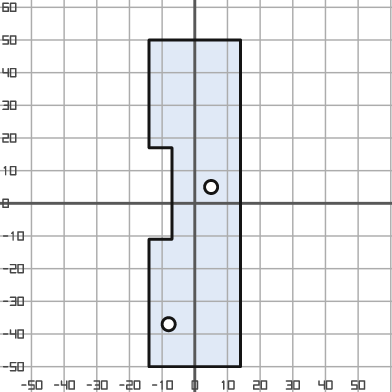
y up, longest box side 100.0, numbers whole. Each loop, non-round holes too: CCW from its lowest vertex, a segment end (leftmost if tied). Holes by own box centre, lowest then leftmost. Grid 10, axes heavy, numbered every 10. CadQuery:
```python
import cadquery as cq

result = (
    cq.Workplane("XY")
    .moveTo(-14.0, -50.0)
    .lineTo(14.0, -50.0)
    .lineTo(14.0, 50.0)
    .lineTo(-14.0, 50.0)
    .lineTo(-14.0, 17.0)
    .lineTo(-7.0, 17.0)
    .lineTo(-7.0, -11.0)
    .lineTo(-14.0, -11.0)
    .close()
    .moveTo(-8.0, -37.0)
    .circle(2.0)
    .moveTo(5.0, 5.0)
    .circle(2.0)
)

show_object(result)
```